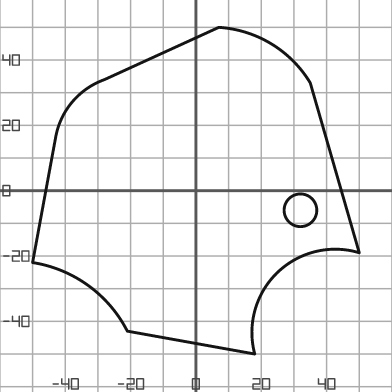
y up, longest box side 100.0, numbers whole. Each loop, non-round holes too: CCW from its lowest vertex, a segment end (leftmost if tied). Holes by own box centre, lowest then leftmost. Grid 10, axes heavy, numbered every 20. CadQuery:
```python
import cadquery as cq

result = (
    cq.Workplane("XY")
    .moveTo(18.0, -50.0)
    .threePointArc((25.0, -25.0), (50.0, -19.0))
    .lineTo(35.0, 33.0)
    .threePointArc((23.0, 45.0), (7.0, 50.0))
    .lineTo(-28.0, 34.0)
    .threePointArc((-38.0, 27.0), (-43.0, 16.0))
    .lineTo(-50.0, -22.0)
    .threePointArc((-33.0, -29.0), (-21.0, -43.0))
    .close()
    .moveTo(32.0, -6.0)
    .circle(5.0)
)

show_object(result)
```